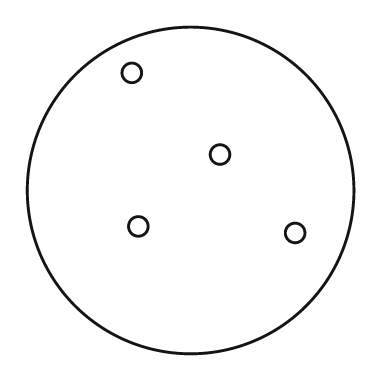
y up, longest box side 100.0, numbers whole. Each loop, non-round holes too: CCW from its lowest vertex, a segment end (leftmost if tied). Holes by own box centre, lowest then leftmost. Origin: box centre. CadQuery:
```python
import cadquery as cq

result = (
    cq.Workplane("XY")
    .moveTo(0.0, 0.0)
    .circle(50.0)
    .moveTo(32.0, -13.0)
    .circle(3.0)
    .moveTo(-16.0, -11.0)
    .circle(3.0)
    .moveTo(9.0, 11.0)
    .circle(3.0)
    .moveTo(-18.0, 36.0)
    .circle(3.0)
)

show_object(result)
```